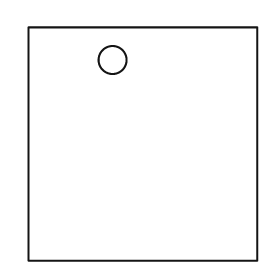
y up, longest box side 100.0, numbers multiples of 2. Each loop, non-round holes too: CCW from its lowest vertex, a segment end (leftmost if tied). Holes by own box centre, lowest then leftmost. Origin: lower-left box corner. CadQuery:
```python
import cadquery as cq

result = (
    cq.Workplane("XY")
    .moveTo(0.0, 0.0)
    .lineTo(98.0, 0.0)
    .lineTo(98.0, 100.0)
    .lineTo(0.0, 100.0)
    .close()
    .moveTo(36.0, 86.0)
    .circle(6.0)
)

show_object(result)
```